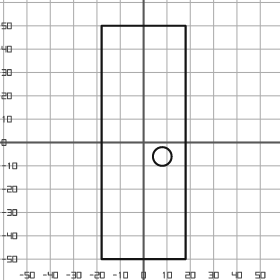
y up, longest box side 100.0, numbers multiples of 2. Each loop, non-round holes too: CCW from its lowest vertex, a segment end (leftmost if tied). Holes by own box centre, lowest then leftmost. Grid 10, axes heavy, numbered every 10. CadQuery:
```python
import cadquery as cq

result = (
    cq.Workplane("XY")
    .moveTo(-18.0, -50.0)
    .lineTo(18.0, -50.0)
    .lineTo(18.0, 50.0)
    .lineTo(-18.0, 50.0)
    .close()
    .moveTo(8.0, -6.0)
    .circle(4.0)
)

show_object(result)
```